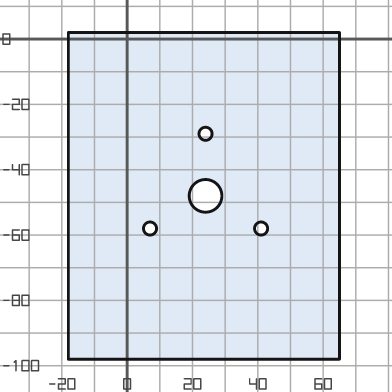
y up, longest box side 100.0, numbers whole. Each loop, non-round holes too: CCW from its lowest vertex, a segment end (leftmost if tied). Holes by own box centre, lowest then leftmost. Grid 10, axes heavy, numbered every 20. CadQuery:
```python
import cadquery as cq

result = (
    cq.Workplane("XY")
    .moveTo(-18.0, -98.0)
    .lineTo(65.0, -98.0)
    .lineTo(65.0, 2.0)
    .lineTo(-18.0, 2.0)
    .close()
    .moveTo(7.0, -58.0)
    .circle(2.0)
    .moveTo(41.0, -58.0)
    .circle(2.0)
    .moveTo(24.0, -48.0)
    .circle(5.0)
    .moveTo(24.0, -29.0)
    .circle(2.0)
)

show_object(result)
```